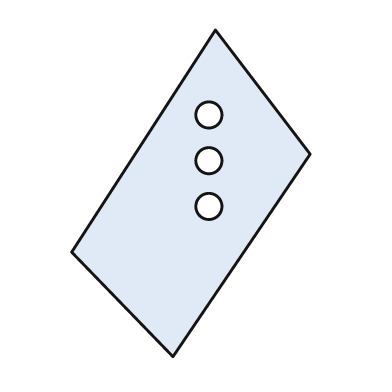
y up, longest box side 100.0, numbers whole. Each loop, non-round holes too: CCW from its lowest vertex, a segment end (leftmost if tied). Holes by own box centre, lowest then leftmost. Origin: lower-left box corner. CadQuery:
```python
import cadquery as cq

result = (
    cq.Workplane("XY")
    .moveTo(31.0, 0.0)
    .lineTo(73.0, 62.0)
    .lineTo(44.0, 100.0)
    .lineTo(0.0, 32.0)
    .close()
    .moveTo(42.0, 46.0)
    .circle(4.0)
    .moveTo(42.0, 60.0)
    .circle(4.0)
    .moveTo(42.0, 74.0)
    .circle(4.0)
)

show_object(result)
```